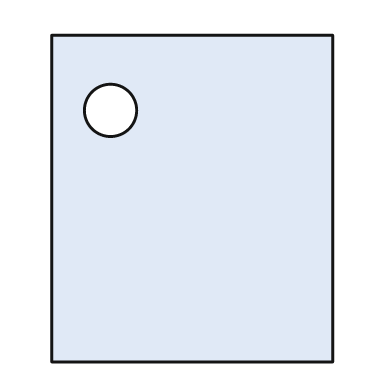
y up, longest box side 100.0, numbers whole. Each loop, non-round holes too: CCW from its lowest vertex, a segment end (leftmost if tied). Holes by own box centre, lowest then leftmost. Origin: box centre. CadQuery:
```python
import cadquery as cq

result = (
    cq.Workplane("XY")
    .moveTo(-43.0, -50.0)
    .lineTo(43.0, -50.0)
    .lineTo(43.0, 50.0)
    .lineTo(-43.0, 50.0)
    .close()
    .moveTo(-25.0, 27.0)
    .circle(8.0)
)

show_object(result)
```